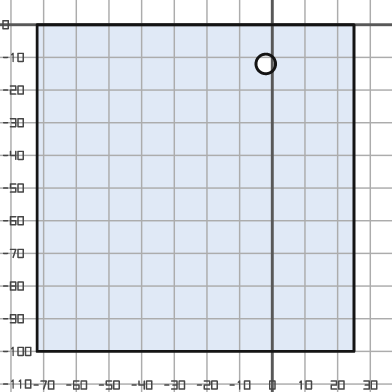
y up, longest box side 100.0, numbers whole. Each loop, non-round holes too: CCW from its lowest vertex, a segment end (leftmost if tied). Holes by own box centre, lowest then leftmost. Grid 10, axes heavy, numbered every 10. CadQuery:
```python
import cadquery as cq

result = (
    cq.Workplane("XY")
    .moveTo(-72.0, -100.0)
    .lineTo(25.0, -100.0)
    .lineTo(25.0, 0.0)
    .lineTo(-72.0, 0.0)
    .close()
    .moveTo(-2.0, -12.0)
    .circle(3.0)
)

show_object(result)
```